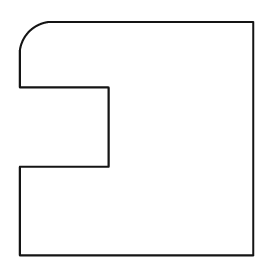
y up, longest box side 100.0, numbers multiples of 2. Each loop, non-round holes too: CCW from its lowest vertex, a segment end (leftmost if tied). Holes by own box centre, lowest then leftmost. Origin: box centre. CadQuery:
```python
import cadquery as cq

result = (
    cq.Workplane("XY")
    .moveTo(-50.0, -50.0)
    .lineTo(50.0, -50.0)
    .lineTo(50.0, 50.0)
    .lineTo(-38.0, 50.0)
    .threePointArc((-46.0, 46.0), (-50.0, 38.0))
    .lineTo(-50.0, 22.0)
    .lineTo(-12.0, 22.0)
    .lineTo(-12.0, -12.0)
    .lineTo(-50.0, -12.0)
    .close()
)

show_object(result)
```